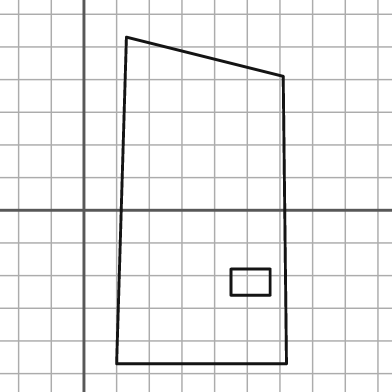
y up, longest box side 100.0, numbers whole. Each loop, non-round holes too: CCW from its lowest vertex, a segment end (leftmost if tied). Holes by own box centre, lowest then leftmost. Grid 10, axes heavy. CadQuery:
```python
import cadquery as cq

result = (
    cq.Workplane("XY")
    .moveTo(10.0, -47.0)
    .lineTo(62.0, -47.0)
    .lineTo(61.0, 41.0)
    .lineTo(13.0, 53.0)
    .close()
    .moveTo(45.0, -26.0)
    .lineTo(57.0, -26.0)
    .lineTo(57.0, -18.0)
    .lineTo(45.0, -18.0)
    .close()
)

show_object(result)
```